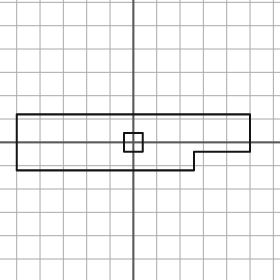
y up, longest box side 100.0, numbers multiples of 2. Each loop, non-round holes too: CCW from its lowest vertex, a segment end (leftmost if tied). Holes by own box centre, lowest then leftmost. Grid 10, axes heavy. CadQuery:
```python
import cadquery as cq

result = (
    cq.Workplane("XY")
    .moveTo(-50.0, -12.0)
    .lineTo(26.0, -12.0)
    .lineTo(26.0, -4.0)
    .lineTo(50.0, -4.0)
    .lineTo(50.0, 12.0)
    .lineTo(-50.0, 12.0)
    .close()
    .moveTo(-4.0, -4.0)
    .lineTo(4.0, -4.0)
    .lineTo(4.0, 4.0)
    .lineTo(-4.0, 4.0)
    .close()
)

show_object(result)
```